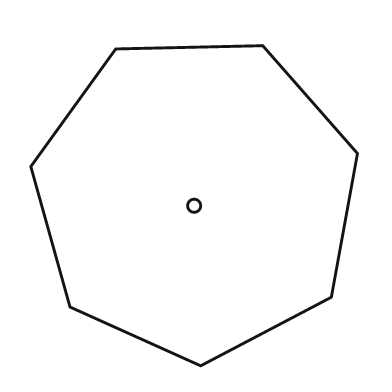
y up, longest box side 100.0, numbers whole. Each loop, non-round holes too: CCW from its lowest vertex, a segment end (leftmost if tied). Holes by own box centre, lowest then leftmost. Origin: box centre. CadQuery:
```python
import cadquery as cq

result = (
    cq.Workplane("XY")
    .moveTo(2.0, -49.0)
    .lineTo(42.0, -28.0)
    .lineTo(50.0, 16.0)
    .lineTo(21.0, 49.0)
    .lineTo(-24.0, 48.0)
    .lineTo(-50.0, 12.0)
    .lineTo(-38.0, -31.0)
    .close()
    .moveTo(0.0, 0.0)
    .circle(2.0)
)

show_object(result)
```